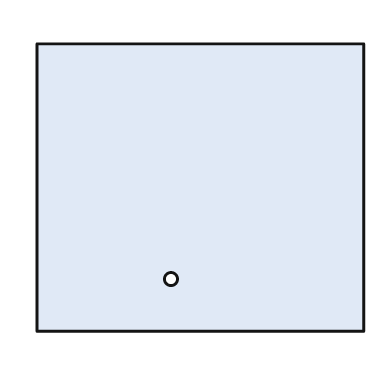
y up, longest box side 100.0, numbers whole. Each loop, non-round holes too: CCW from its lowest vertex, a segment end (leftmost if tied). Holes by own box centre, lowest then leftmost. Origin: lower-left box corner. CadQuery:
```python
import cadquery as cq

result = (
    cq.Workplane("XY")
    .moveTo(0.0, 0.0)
    .lineTo(100.0, 0.0)
    .lineTo(100.0, 88.0)
    .lineTo(0.0, 88.0)
    .close()
    .moveTo(41.0, 16.0)
    .circle(2.0)
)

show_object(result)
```